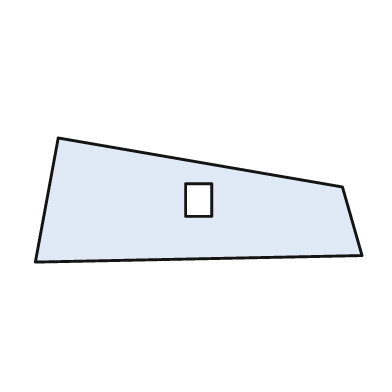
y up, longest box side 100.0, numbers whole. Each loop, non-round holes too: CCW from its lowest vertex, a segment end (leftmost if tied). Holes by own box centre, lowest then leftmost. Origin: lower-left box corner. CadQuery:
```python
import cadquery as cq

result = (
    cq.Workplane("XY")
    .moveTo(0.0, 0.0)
    .lineTo(100.0, 2.0)
    .lineTo(94.0, 23.0)
    .lineTo(7.0, 38.0)
    .close()
    .moveTo(46.0, 14.0)
    .lineTo(54.0, 14.0)
    .lineTo(54.0, 24.0)
    .lineTo(46.0, 24.0)
    .close()
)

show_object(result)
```